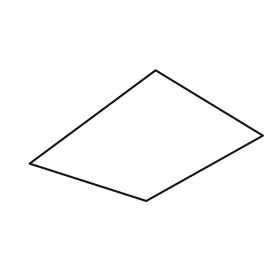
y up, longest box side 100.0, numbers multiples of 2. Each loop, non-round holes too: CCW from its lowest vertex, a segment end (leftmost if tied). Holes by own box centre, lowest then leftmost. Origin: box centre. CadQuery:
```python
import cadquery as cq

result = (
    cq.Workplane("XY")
    .moveTo(0.0, -28.0)
    .lineTo(50.0, 0.0)
    .lineTo(4.0, 28.0)
    .lineTo(-50.0, -12.0)
    .close()
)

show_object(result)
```